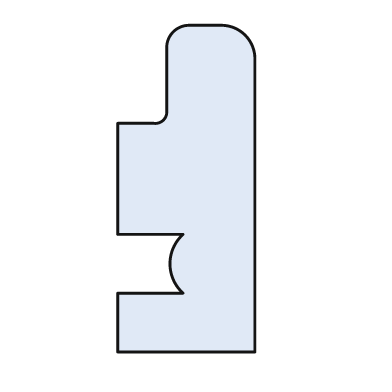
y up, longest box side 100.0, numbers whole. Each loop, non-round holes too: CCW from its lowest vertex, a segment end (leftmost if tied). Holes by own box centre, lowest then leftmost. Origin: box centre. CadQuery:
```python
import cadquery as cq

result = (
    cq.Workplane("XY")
    .moveTo(-21.0, -50.0)
    .lineTo(21.0, -50.0)
    .lineTo(21.0, 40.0)
    .threePointArc((18.0, 47.0), (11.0, 50.0))
    .lineTo(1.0, 50.0)
    .threePointArc((-4.0, 48.0), (-6.0, 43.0))
    .lineTo(-6.0, 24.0)
    .threePointArc((-7.0, 21.0), (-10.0, 20.0))
    .lineTo(-21.0, 20.0)
    .lineTo(-21.0, -14.0)
    .lineTo(-1.0, -14.0)
    .threePointArc((-5.0, -23.0), (-1.0, -32.0))
    .lineTo(-21.0, -32.0)
    .close()
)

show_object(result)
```